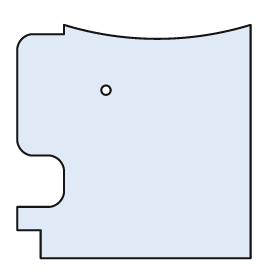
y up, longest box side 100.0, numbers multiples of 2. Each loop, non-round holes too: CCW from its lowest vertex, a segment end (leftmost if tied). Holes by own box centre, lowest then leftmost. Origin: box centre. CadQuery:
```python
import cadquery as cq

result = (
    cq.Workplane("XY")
    .moveTo(-40.0, -50.0)
    .lineTo(50.0, -50.0)
    .lineTo(50.0, 50.0)
    .threePointArc((10.0, 44.0), (-30.0, 50.0))
    .lineTo(-30.0, 46.0)
    .lineTo(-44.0, 46.0)
    .threePointArc((-48.0, 44.0), (-50.0, 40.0))
    .lineTo(-50.0, 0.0)
    .threePointArc((-48.0, -4.0), (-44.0, -6.0))
    .lineTo(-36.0, -6.0)
    .threePointArc((-32.0, -8.0), (-30.0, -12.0))
    .lineTo(-30.0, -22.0)
    .threePointArc((-32.0, -26.0), (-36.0, -28.0))
    .lineTo(-50.0, -28.0)
    .lineTo(-50.0, -38.0)
    .lineTo(-40.0, -38.0)
    .close()
    .moveTo(-12.0, 22.0)
    .circle(2.0)
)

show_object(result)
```